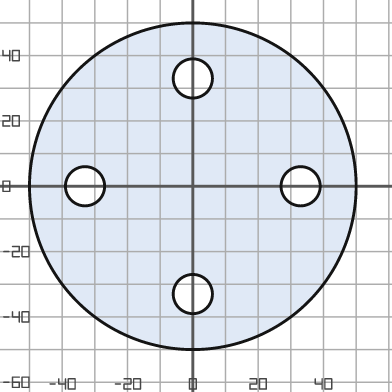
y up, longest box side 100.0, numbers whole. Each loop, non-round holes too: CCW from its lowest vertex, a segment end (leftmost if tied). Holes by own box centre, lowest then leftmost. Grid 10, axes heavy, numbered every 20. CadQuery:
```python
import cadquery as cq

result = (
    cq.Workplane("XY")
    .moveTo(0.0, 0.0)
    .circle(50.0)
    .moveTo(0.0, -33.0)
    .circle(6.0)
    .moveTo(-33.0, 0.0)
    .circle(6.0)
    .moveTo(33.0, 0.0)
    .circle(6.0)
    .moveTo(0.0, 33.0)
    .circle(6.0)
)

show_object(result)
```